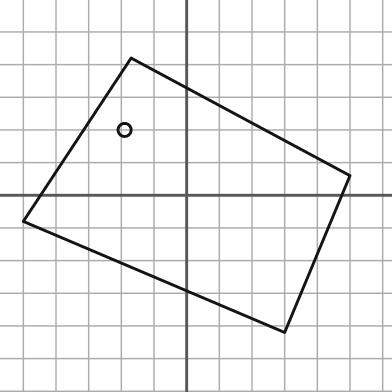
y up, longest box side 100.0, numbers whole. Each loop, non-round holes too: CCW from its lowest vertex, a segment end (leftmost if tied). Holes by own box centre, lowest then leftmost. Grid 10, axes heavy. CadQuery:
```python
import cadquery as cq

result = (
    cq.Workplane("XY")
    .moveTo(30.0, -42.0)
    .lineTo(50.0, 6.0)
    .lineTo(-17.0, 42.0)
    .lineTo(-50.0, -8.0)
    .close()
    .moveTo(-19.0, 20.0)
    .circle(2.0)
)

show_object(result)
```